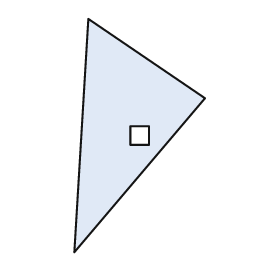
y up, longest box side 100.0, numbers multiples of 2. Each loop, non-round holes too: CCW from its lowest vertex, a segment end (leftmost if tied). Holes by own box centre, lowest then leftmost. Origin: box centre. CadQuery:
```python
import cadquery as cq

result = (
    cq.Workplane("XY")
    .moveTo(-28.0, -50.0)
    .lineTo(28.0, 16.0)
    .lineTo(-22.0, 50.0)
    .close()
    .moveTo(-4.0, -4.0)
    .lineTo(4.0, -4.0)
    .lineTo(4.0, 4.0)
    .lineTo(-4.0, 4.0)
    .close()
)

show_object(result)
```